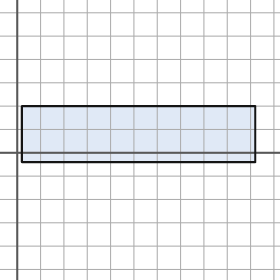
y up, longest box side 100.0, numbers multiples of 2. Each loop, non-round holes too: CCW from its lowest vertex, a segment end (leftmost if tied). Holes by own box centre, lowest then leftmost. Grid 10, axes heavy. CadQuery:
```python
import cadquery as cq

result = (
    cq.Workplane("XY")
    .moveTo(2.0, -4.0)
    .lineTo(102.0, -4.0)
    .lineTo(102.0, 20.0)
    .lineTo(2.0, 20.0)
    .close()
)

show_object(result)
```